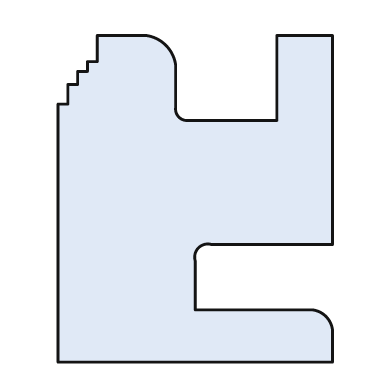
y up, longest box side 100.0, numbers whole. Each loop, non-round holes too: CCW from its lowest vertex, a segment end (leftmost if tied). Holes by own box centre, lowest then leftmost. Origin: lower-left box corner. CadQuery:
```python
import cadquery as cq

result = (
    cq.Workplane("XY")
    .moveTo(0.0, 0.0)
    .lineTo(84.0, 0.0)
    .lineTo(84.0, 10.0)
    .threePointArc((82.0, 14.0), (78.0, 16.0))
    .lineTo(42.0, 16.0)
    .lineTo(42.0, 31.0)
    .threePointArc((43.0, 35.0), (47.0, 36.0))
    .lineTo(84.0, 36.0)
    .lineTo(84.0, 100.0)
    .lineTo(67.0, 100.0)
    .lineTo(67.0, 74.0)
    .lineTo(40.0, 74.0)
    .threePointArc((37.0, 75.0), (36.0, 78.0))
    .lineTo(36.0, 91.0)
    .threePointArc((33.0, 97.0), (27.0, 100.0))
    .lineTo(12.0, 100.0)
    .lineTo(12.0, 92.0)
    .lineTo(9.0, 92.0)
    .lineTo(9.0, 89.0)
    .lineTo(6.0, 89.0)
    .lineTo(6.0, 85.0)
    .lineTo(3.0, 85.0)
    .lineTo(3.0, 79.0)
    .lineTo(0.0, 79.0)
    .close()
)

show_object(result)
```